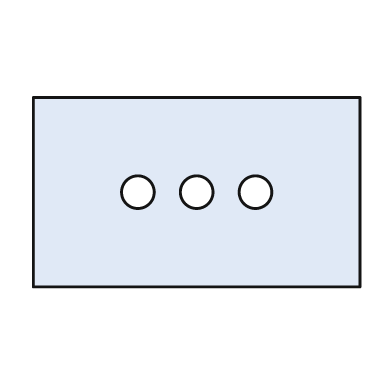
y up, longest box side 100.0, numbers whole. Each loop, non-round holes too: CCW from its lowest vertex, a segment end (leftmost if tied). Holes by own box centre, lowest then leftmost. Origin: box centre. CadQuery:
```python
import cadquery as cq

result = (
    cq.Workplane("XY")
    .moveTo(-50.0, -29.0)
    .lineTo(50.0, -29.0)
    .lineTo(50.0, 29.0)
    .lineTo(-50.0, 29.0)
    .close()
    .moveTo(-18.0, 0.0)
    .circle(5.0)
    .moveTo(0.0, 0.0)
    .circle(5.0)
    .moveTo(18.0, 0.0)
    .circle(5.0)
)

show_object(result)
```